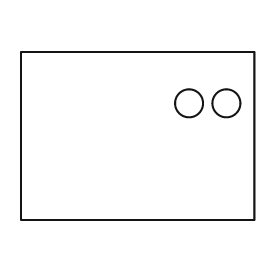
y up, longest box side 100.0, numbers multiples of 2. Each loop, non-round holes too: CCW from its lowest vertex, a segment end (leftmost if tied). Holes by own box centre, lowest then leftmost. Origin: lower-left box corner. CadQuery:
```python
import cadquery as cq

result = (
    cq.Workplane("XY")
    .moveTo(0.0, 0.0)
    .lineTo(100.0, 0.0)
    .lineTo(100.0, 72.0)
    .lineTo(0.0, 72.0)
    .close()
    .moveTo(72.0, 50.0)
    .circle(6.0)
    .moveTo(88.0, 50.0)
    .circle(6.0)
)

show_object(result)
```